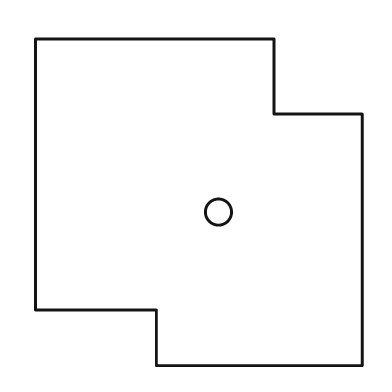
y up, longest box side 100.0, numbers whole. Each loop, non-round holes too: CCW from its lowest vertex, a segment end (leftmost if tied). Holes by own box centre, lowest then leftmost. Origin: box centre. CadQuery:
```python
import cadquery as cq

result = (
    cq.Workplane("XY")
    .moveTo(-13.0, -50.0)
    .lineTo(50.0, -50.0)
    .lineTo(50.0, 27.0)
    .lineTo(23.0, 27.0)
    .lineTo(23.0, 50.0)
    .lineTo(-50.0, 50.0)
    .lineTo(-50.0, -33.0)
    .lineTo(-13.0, -33.0)
    .close()
    .moveTo(6.0, -3.0)
    .circle(4.0)
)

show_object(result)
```